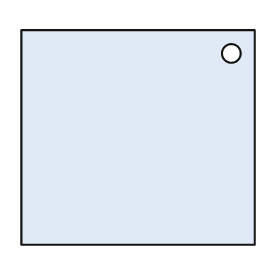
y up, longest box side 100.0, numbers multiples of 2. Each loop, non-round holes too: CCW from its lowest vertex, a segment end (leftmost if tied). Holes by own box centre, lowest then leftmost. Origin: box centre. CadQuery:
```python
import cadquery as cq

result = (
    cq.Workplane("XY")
    .moveTo(-50.0, -46.0)
    .lineTo(50.0, -46.0)
    .lineTo(50.0, 46.0)
    .lineTo(-50.0, 46.0)
    .close()
    .moveTo(40.0, 36.0)
    .circle(4.0)
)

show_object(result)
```